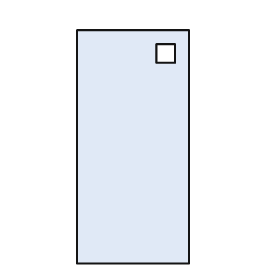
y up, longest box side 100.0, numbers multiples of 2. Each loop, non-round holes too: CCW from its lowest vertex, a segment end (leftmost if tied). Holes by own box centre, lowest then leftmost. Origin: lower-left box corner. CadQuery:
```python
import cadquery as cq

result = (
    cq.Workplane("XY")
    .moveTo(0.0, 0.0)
    .lineTo(48.0, 0.0)
    .lineTo(48.0, 100.0)
    .lineTo(0.0, 100.0)
    .close()
    .moveTo(34.0, 86.0)
    .lineTo(42.0, 86.0)
    .lineTo(42.0, 94.0)
    .lineTo(34.0, 94.0)
    .close()
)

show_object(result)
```